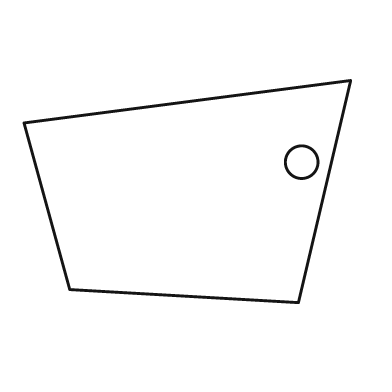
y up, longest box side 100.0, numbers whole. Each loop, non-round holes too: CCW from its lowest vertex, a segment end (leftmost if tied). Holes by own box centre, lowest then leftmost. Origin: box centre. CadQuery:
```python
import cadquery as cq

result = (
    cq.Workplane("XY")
    .moveTo(34.0, -34.0)
    .lineTo(50.0, 34.0)
    .lineTo(-50.0, 21.0)
    .lineTo(-36.0, -30.0)
    .close()
    .moveTo(35.0, 9.0)
    .circle(5.0)
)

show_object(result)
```